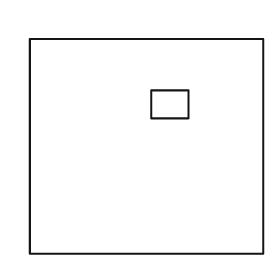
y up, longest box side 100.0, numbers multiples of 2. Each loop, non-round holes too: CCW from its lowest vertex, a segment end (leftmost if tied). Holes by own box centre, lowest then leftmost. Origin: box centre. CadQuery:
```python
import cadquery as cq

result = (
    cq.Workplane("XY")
    .moveTo(-50.0, -46.0)
    .lineTo(50.0, -46.0)
    .lineTo(50.0, 46.0)
    .lineTo(-50.0, 46.0)
    .close()
    .moveTo(2.0, 12.0)
    .lineTo(18.0, 12.0)
    .lineTo(18.0, 24.0)
    .lineTo(2.0, 24.0)
    .close()
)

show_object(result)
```